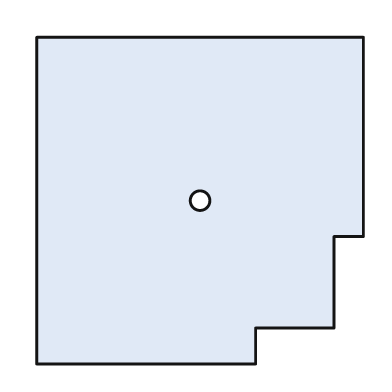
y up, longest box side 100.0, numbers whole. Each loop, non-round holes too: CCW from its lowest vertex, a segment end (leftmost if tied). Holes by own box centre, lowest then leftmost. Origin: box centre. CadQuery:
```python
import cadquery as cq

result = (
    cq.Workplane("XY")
    .moveTo(-50.0, -50.0)
    .lineTo(17.0, -50.0)
    .lineTo(17.0, -39.0)
    .lineTo(41.0, -39.0)
    .lineTo(41.0, -11.0)
    .lineTo(50.0, -11.0)
    .lineTo(50.0, 50.0)
    .lineTo(-50.0, 50.0)
    .close()
    .moveTo(0.0, 0.0)
    .circle(3.0)
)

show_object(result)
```